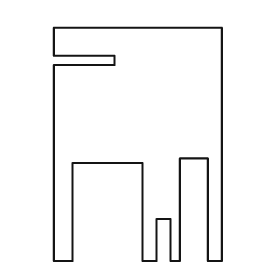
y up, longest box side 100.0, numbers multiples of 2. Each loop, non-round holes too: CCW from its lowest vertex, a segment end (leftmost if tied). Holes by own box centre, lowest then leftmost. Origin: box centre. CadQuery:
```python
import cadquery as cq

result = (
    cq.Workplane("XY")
    .moveTo(-36.0, -50.0)
    .lineTo(-28.0, -50.0)
    .lineTo(-28.0, -8.0)
    .lineTo(2.0, -8.0)
    .lineTo(2.0, -50.0)
    .lineTo(8.0, -50.0)
    .lineTo(8.0, -32.0)
    .lineTo(14.0, -32.0)
    .lineTo(14.0, -50.0)
    .lineTo(18.0, -50.0)
    .lineTo(18.0, -6.0)
    .lineTo(30.0, -6.0)
    .lineTo(30.0, -50.0)
    .lineTo(36.0, -50.0)
    .lineTo(36.0, 50.0)
    .lineTo(-36.0, 50.0)
    .lineTo(-36.0, 38.0)
    .lineTo(-10.0, 38.0)
    .lineTo(-10.0, 34.0)
    .lineTo(-36.0, 34.0)
    .close()
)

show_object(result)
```